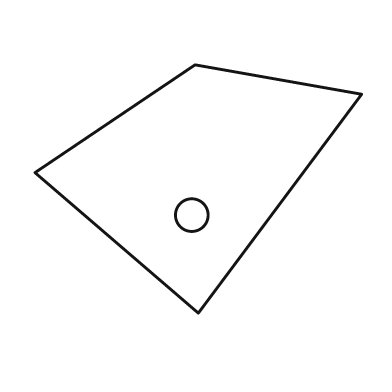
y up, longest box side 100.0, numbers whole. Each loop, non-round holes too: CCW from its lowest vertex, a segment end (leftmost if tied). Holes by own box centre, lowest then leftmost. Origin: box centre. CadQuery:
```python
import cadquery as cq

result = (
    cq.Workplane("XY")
    .moveTo(0.0, -38.0)
    .lineTo(50.0, 29.0)
    .lineTo(-1.0, 38.0)
    .lineTo(-50.0, 5.0)
    .close()
    .moveTo(-2.0, -8.0)
    .circle(5.0)
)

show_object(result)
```